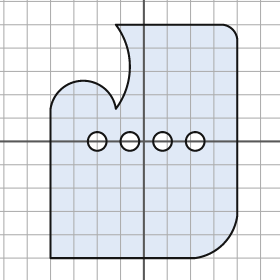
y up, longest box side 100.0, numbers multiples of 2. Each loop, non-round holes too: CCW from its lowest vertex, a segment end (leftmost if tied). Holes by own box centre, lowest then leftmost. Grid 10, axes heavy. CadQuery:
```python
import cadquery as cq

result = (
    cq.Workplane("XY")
    .moveTo(-40.0, -50.0)
    .lineTo(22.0, -50.0)
    .threePointArc((34.0, -44.0), (40.0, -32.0))
    .lineTo(40.0, 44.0)
    .threePointArc((38.0, 48.0), (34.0, 50.0))
    .lineTo(-12.0, 50.0)
    .threePointArc((-6.0, 32.0), (-12.0, 14.0))
    .threePointArc((-26.0, 26.0), (-40.0, 14.0))
    .close()
    .moveTo(-20.0, 0.0)
    .circle(4.0)
    .moveTo(-6.0, 0.0)
    .circle(4.0)
    .moveTo(8.0, 0.0)
    .circle(4.0)
    .moveTo(22.0, 0.0)
    .circle(4.0)
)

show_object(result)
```